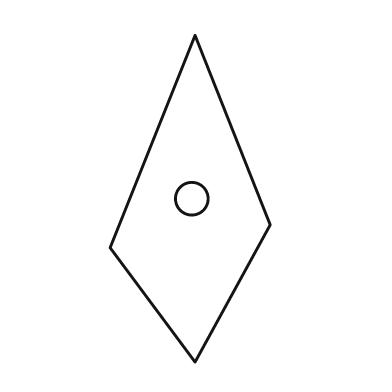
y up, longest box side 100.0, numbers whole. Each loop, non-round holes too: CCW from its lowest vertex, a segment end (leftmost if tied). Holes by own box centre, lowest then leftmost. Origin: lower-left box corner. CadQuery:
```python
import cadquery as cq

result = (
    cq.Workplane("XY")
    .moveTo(26.0, 0.0)
    .lineTo(49.0, 42.0)
    .lineTo(26.0, 100.0)
    .lineTo(0.0, 35.0)
    .close()
    .moveTo(25.0, 50.0)
    .circle(5.0)
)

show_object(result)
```